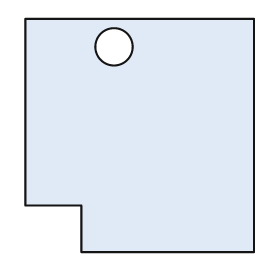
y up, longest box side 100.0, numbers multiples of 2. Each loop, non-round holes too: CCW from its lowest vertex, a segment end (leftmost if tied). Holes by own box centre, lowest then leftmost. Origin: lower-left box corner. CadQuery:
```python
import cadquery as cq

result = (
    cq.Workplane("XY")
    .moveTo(24.0, 0.0)
    .lineTo(98.0, 0.0)
    .lineTo(98.0, 100.0)
    .lineTo(0.0, 100.0)
    .lineTo(0.0, 20.0)
    .lineTo(24.0, 20.0)
    .close()
    .moveTo(38.0, 88.0)
    .circle(8.0)
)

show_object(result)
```